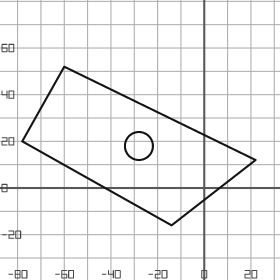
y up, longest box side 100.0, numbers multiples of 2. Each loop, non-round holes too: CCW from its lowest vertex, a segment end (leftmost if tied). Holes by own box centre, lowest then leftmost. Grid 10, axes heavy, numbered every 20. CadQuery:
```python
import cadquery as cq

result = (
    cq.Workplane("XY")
    .moveTo(-14.0, -16.0)
    .lineTo(22.0, 12.0)
    .lineTo(-60.0, 52.0)
    .lineTo(-78.0, 20.0)
    .close()
    .moveTo(-28.0, 18.0)
    .circle(6.0)
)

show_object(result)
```